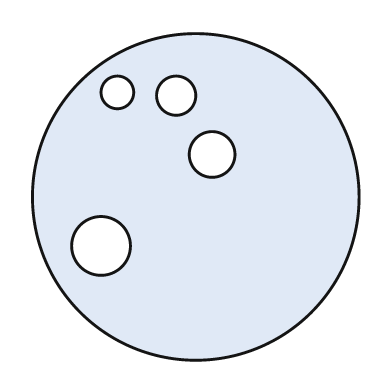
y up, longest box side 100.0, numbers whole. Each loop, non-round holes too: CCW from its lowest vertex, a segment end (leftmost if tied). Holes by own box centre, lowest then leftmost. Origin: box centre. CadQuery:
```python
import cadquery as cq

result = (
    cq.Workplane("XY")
    .moveTo(0.0, 0.0)
    .circle(50.0)
    .moveTo(-29.0, -15.0)
    .circle(9.0)
    .moveTo(5.0, 13.0)
    .circle(7.0)
    .moveTo(-6.0, 31.0)
    .circle(6.0)
    .moveTo(-24.0, 32.0)
    .circle(5.0)
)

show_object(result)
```